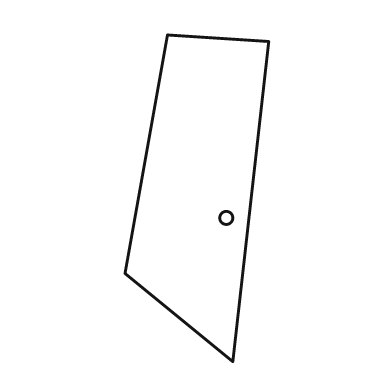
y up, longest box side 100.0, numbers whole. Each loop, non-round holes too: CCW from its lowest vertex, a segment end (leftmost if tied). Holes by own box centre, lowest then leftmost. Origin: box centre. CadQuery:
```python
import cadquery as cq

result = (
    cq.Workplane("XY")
    .moveTo(11.0, -50.0)
    .lineTo(22.0, 48.0)
    .lineTo(-9.0, 50.0)
    .lineTo(-22.0, -23.0)
    .close()
    .moveTo(9.0, -6.0)
    .circle(2.0)
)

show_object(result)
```